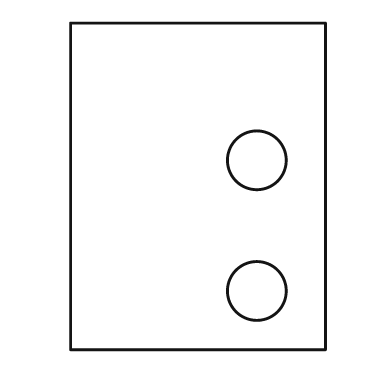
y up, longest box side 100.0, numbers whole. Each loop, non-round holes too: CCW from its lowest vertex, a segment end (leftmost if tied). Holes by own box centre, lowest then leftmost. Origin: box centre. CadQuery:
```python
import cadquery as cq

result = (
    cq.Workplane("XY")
    .moveTo(-39.0, -50.0)
    .lineTo(39.0, -50.0)
    .lineTo(39.0, 50.0)
    .lineTo(-39.0, 50.0)
    .close()
    .moveTo(18.0, -32.0)
    .circle(9.0)
    .moveTo(18.0, 8.0)
    .circle(9.0)
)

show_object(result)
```